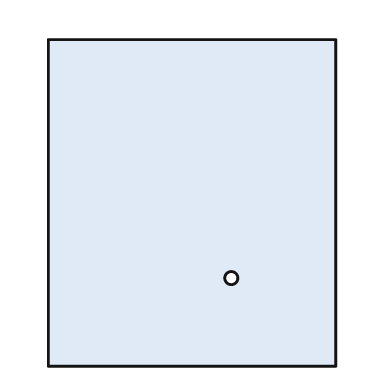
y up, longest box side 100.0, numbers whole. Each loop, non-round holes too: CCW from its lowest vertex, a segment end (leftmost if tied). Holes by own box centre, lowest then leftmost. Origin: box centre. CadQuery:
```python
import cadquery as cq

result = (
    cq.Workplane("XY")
    .moveTo(-44.0, -50.0)
    .lineTo(44.0, -50.0)
    .lineTo(44.0, 50.0)
    .lineTo(-44.0, 50.0)
    .close()
    .moveTo(12.0, -23.0)
    .circle(2.0)
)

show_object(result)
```